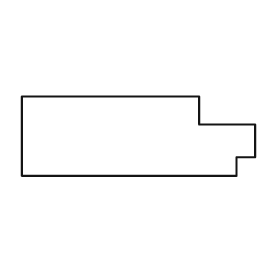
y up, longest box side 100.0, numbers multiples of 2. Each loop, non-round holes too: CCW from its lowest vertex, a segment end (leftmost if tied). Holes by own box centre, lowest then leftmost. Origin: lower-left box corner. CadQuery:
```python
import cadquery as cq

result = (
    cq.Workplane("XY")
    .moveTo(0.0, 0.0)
    .lineTo(92.0, 0.0)
    .lineTo(92.0, 8.0)
    .lineTo(100.0, 8.0)
    .lineTo(100.0, 22.0)
    .lineTo(76.0, 22.0)
    .lineTo(76.0, 34.0)
    .lineTo(0.0, 34.0)
    .close()
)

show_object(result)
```